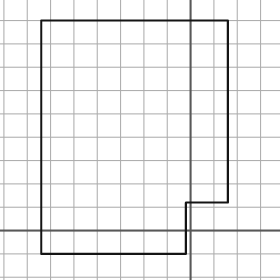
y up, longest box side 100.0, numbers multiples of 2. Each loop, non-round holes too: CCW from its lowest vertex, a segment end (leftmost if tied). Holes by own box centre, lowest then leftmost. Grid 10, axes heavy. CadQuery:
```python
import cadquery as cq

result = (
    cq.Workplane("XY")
    .moveTo(-64.0, -10.0)
    .lineTo(-2.0, -10.0)
    .lineTo(-2.0, 12.0)
    .lineTo(16.0, 12.0)
    .lineTo(16.0, 90.0)
    .lineTo(-64.0, 90.0)
    .close()
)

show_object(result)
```